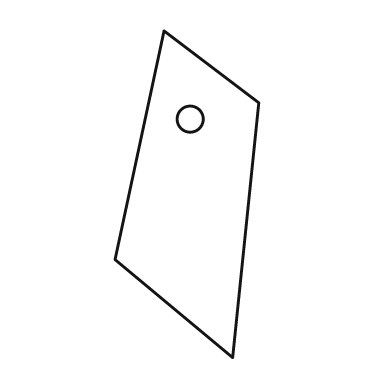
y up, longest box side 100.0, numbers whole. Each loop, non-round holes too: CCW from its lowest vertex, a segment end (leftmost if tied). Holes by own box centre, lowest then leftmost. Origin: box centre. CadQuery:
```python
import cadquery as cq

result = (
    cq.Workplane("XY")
    .moveTo(14.0, -50.0)
    .lineTo(22.0, 28.0)
    .lineTo(-7.0, 50.0)
    .lineTo(-22.0, -20.0)
    .close()
    .moveTo(1.0, 23.0)
    .circle(4.0)
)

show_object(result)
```